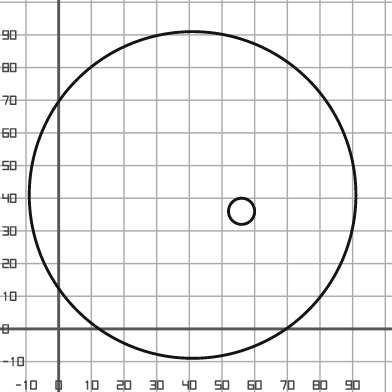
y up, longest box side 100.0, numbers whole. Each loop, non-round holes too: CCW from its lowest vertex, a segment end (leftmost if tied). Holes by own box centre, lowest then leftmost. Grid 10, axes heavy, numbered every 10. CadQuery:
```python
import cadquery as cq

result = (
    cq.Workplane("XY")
    .moveTo(41.0, 41.0)
    .circle(50.0)
    .moveTo(56.0, 36.0)
    .circle(4.0)
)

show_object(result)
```